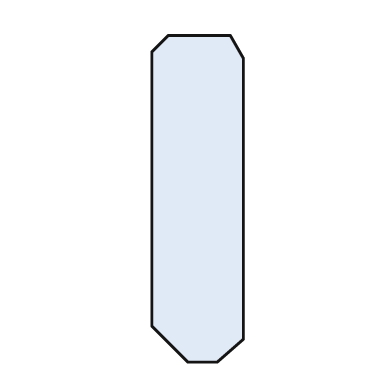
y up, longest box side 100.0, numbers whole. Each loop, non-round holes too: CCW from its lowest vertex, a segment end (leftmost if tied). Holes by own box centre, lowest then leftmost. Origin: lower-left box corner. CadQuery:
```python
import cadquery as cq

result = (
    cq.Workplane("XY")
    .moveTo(11.0, 0.0)
    .lineTo(20.0, 0.0)
    .lineTo(28.0, 7.0)
    .lineTo(28.0, 93.0)
    .lineTo(24.0, 100.0)
    .lineTo(5.0, 100.0)
    .lineTo(0.0, 95.0)
    .lineTo(0.0, 11.0)
    .close()
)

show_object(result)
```